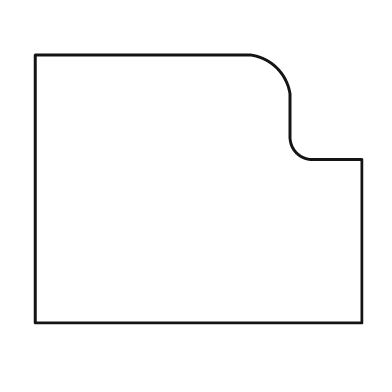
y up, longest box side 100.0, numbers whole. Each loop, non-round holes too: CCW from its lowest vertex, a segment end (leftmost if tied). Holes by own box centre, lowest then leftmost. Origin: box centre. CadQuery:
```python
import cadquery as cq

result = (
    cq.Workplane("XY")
    .moveTo(-50.0, -41.0)
    .lineTo(50.0, -41.0)
    .lineTo(50.0, 9.0)
    .lineTo(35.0, 9.0)
    .threePointArc((30.0, 11.0), (28.0, 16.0))
    .lineTo(28.0, 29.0)
    .threePointArc((24.0, 37.0), (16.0, 41.0))
    .lineTo(-50.0, 41.0)
    .close()
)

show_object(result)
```